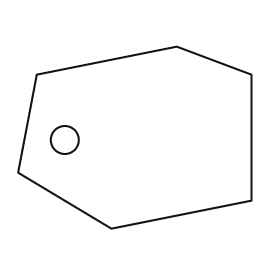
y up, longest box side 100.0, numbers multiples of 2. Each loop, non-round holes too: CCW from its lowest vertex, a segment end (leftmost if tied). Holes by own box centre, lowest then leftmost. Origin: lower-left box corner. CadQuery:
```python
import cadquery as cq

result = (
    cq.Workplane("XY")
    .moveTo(40.0, 0.0)
    .lineTo(100.0, 12.0)
    .lineTo(100.0, 66.0)
    .lineTo(68.0, 78.0)
    .lineTo(8.0, 66.0)
    .lineTo(0.0, 24.0)
    .close()
    .moveTo(20.0, 38.0)
    .circle(6.0)
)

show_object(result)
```